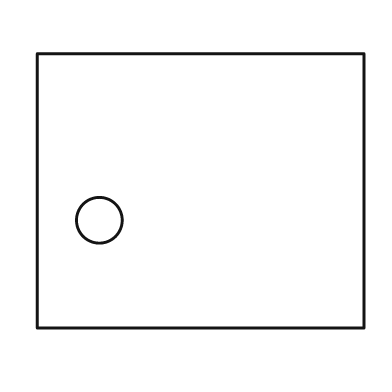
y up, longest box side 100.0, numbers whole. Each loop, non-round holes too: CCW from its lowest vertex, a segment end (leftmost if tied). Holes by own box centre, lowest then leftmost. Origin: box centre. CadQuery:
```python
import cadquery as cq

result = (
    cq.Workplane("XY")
    .moveTo(-50.0, -42.0)
    .lineTo(50.0, -42.0)
    .lineTo(50.0, 42.0)
    .lineTo(-50.0, 42.0)
    .close()
    .moveTo(-31.0, -9.0)
    .circle(7.0)
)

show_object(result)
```